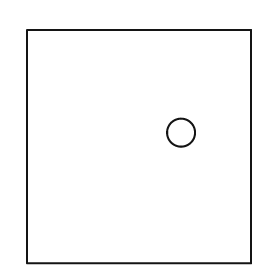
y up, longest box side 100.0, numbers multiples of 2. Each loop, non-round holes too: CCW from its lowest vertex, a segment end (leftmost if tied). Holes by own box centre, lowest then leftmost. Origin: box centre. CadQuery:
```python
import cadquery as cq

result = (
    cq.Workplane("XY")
    .moveTo(-48.0, -50.0)
    .lineTo(48.0, -50.0)
    .lineTo(48.0, 50.0)
    .lineTo(-48.0, 50.0)
    .close()
    .moveTo(18.0, 6.0)
    .circle(6.0)
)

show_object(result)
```